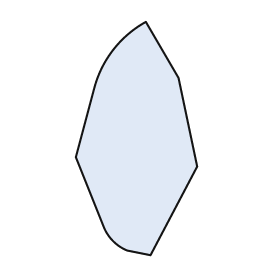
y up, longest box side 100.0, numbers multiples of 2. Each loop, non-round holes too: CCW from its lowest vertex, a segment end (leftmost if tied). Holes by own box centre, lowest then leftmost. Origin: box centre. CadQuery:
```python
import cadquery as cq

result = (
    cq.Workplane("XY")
    .moveTo(6.0, -50.0)
    .lineTo(26.0, -12.0)
    .lineTo(18.0, 26.0)
    .lineTo(4.0, 50.0)
    .threePointArc((-10.0, 38.0), (-18.0, 22.0))
    .lineTo(-26.0, -8.0)
    .lineTo(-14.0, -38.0)
    .threePointArc((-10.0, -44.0), (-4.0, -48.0))
    .close()
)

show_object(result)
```